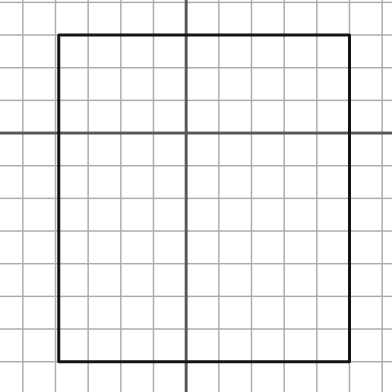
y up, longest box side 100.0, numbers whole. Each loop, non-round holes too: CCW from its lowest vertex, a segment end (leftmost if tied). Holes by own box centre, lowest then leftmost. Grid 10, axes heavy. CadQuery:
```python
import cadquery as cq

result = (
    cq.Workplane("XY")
    .moveTo(-39.0, -70.0)
    .lineTo(50.0, -70.0)
    .lineTo(50.0, 30.0)
    .lineTo(-39.0, 30.0)
    .close()
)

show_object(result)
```